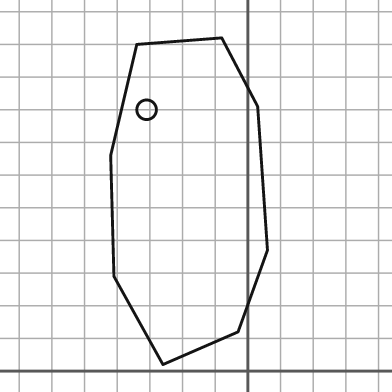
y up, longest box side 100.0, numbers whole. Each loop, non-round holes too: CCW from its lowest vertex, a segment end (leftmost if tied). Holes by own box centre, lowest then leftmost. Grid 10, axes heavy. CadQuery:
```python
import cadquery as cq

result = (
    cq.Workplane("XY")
    .moveTo(-26.0, 2.0)
    .lineTo(-3.0, 12.0)
    .lineTo(6.0, 37.0)
    .lineTo(3.0, 81.0)
    .lineTo(-8.0, 102.0)
    .lineTo(-34.0, 100.0)
    .lineTo(-42.0, 66.0)
    .lineTo(-41.0, 29.0)
    .close()
    .moveTo(-31.0, 80.0)
    .circle(3.0)
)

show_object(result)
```